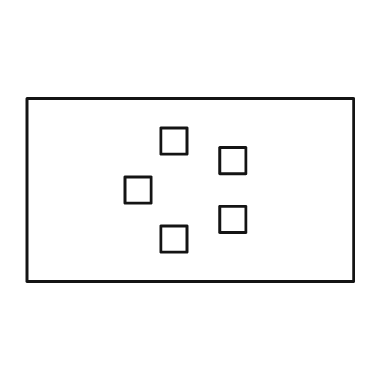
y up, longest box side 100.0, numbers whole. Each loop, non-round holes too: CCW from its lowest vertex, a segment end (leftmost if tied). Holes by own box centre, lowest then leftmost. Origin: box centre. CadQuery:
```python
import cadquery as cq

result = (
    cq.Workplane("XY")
    .moveTo(-50.0, -28.0)
    .lineTo(50.0, -28.0)
    .lineTo(50.0, 28.0)
    .lineTo(-50.0, 28.0)
    .close()
    .moveTo(-9.0, -19.0)
    .lineTo(-1.0, -19.0)
    .lineTo(-1.0, -11.0)
    .lineTo(-9.0, -11.0)
    .close()
    .moveTo(9.0, -13.0)
    .lineTo(17.0, -13.0)
    .lineTo(17.0, -5.0)
    .lineTo(9.0, -5.0)
    .close()
    .moveTo(-20.0, -4.0)
    .lineTo(-12.0, -4.0)
    .lineTo(-12.0, 4.0)
    .lineTo(-20.0, 4.0)
    .close()
    .moveTo(9.0, 5.0)
    .lineTo(17.0, 5.0)
    .lineTo(17.0, 13.0)
    .lineTo(9.0, 13.0)
    .close()
    .moveTo(-9.0, 11.0)
    .lineTo(-1.0, 11.0)
    .lineTo(-1.0, 19.0)
    .lineTo(-9.0, 19.0)
    .close()
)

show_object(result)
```